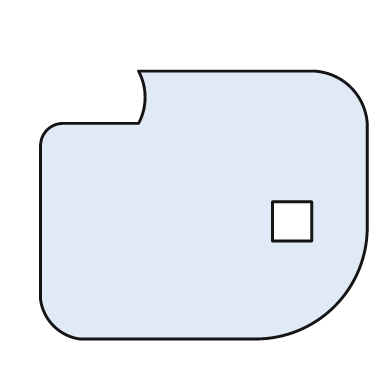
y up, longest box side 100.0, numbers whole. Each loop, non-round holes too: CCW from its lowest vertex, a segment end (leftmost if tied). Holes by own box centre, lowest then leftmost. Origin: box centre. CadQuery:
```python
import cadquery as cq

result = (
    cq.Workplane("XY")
    .moveTo(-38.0, -41.0)
    .lineTo(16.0, -41.0)
    .threePointArc((40.0, -31.0), (50.0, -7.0))
    .lineTo(50.0, 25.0)
    .threePointArc((45.0, 36.0), (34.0, 41.0))
    .lineTo(-20.0, 41.0)
    .threePointArc((-18.0, 33.0), (-20.0, 25.0))
    .lineTo(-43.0, 25.0)
    .threePointArc((-48.0, 23.0), (-50.0, 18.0))
    .lineTo(-50.0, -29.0)
    .threePointArc((-46.0, -37.0), (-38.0, -41.0))
    .close()
    .moveTo(21.0, -11.0)
    .lineTo(33.0, -11.0)
    .lineTo(33.0, 1.0)
    .lineTo(21.0, 1.0)
    .close()
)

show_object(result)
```